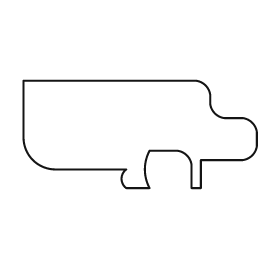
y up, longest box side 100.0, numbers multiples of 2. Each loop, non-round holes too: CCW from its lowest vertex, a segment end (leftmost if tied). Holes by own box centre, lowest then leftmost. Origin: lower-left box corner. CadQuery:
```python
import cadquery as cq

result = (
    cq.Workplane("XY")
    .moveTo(44.0, 0.0)
    .lineTo(54.0, 0.0)
    .threePointArc((52.0, 8.0), (54.0, 16.0))
    .lineTo(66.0, 16.0)
    .threePointArc((70.0, 14.0), (72.0, 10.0))
    .lineTo(72.0, 0.0)
    .lineTo(76.0, 0.0)
    .lineTo(76.0, 12.0)
    .lineTo(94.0, 12.0)
    .threePointArc((98.0, 14.0), (100.0, 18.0))
    .lineTo(100.0, 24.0)
    .threePointArc((98.0, 28.0), (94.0, 30.0))
    .lineTo(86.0, 30.0)
    .threePointArc((82.0, 32.0), (80.0, 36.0))
    .lineTo(80.0, 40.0)
    .threePointArc((78.0, 44.0), (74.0, 46.0))
    .lineTo(0.0, 46.0)
    .lineTo(0.0, 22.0)
    .threePointArc((4.0, 12.0), (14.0, 8.0))
    .lineTo(44.0, 8.0)
    .threePointArc((42.0, 4.0), (44.0, 0.0))
    .close()
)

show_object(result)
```